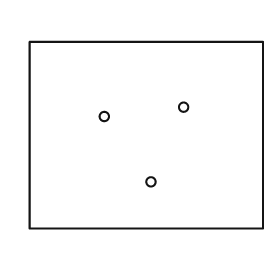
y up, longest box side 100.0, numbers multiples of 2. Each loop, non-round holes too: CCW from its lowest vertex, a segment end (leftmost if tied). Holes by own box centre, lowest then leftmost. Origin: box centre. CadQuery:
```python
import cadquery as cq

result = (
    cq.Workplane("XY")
    .moveTo(-50.0, -40.0)
    .lineTo(50.0, -40.0)
    .lineTo(50.0, 40.0)
    .lineTo(-50.0, 40.0)
    .close()
    .moveTo(2.0, -20.0)
    .circle(2.0)
    .moveTo(-18.0, 8.0)
    .circle(2.0)
    .moveTo(16.0, 12.0)
    .circle(2.0)
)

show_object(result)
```